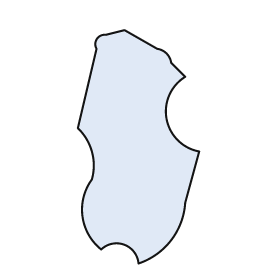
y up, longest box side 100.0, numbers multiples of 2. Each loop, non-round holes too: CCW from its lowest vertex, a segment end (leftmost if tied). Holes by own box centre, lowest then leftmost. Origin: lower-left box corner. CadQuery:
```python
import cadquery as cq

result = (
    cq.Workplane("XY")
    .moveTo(26.0, 0.0)
    .threePointArc((40.0, 10.0), (46.0, 26.0))
    .lineTo(52.0, 48.0)
    .threePointArc((38.0, 62.0), (46.0, 80.0))
    .lineTo(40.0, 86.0)
    .threePointArc((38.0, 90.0), (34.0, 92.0))
    .lineTo(20.0, 100.0)
    .lineTo(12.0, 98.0)
    .threePointArc((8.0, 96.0), (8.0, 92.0))
    .lineTo(0.0, 58.0)
    .threePointArc((6.0, 48.0), (6.0, 36.0))
    .threePointArc((2.0, 20.0), (10.0, 6.0))
    .threePointArc((20.0, 8.0), (26.0, 0.0))
    .close()
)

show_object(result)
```